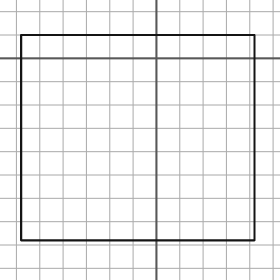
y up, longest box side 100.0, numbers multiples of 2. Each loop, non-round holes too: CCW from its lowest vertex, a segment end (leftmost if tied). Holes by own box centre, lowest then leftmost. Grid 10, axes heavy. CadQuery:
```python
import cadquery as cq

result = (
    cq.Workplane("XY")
    .moveTo(-58.0, -78.0)
    .lineTo(42.0, -78.0)
    .lineTo(42.0, 10.0)
    .lineTo(-58.0, 10.0)
    .close()
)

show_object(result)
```